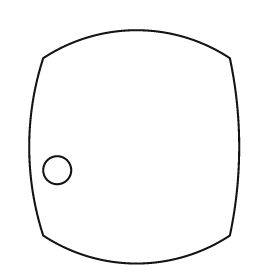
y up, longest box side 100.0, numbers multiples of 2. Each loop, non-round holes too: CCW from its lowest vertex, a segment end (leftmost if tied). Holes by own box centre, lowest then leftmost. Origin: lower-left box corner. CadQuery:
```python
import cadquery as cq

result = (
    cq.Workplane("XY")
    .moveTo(6.0, 12.0)
    .threePointArc((46.0, 0.0), (86.0, 12.0))
    .threePointArc((90.0, 50.0), (86.0, 88.0))
    .threePointArc((46.0, 100.0), (6.0, 88.0))
    .threePointArc((0.0, 50.0), (6.0, 12.0))
    .close()
    .moveTo(12.0, 40.0)
    .circle(6.0)
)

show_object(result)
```